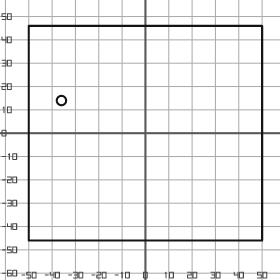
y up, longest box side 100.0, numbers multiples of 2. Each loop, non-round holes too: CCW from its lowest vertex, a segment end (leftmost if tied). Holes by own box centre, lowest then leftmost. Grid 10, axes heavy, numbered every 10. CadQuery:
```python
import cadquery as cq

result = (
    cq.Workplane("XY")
    .moveTo(-50.0, -46.0)
    .lineTo(50.0, -46.0)
    .lineTo(50.0, 46.0)
    .lineTo(-50.0, 46.0)
    .close()
    .moveTo(-36.0, 14.0)
    .circle(2.0)
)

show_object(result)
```